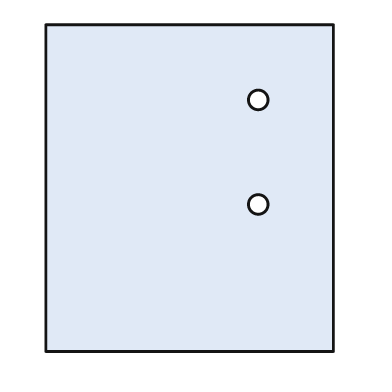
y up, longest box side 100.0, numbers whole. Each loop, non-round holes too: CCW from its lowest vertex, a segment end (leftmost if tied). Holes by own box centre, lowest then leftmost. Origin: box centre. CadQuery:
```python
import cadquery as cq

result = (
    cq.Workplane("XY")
    .moveTo(-44.0, -50.0)
    .lineTo(44.0, -50.0)
    .lineTo(44.0, 50.0)
    .lineTo(-44.0, 50.0)
    .close()
    .moveTo(21.0, -5.0)
    .circle(3.0)
    .moveTo(21.0, 27.0)
    .circle(3.0)
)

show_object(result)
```